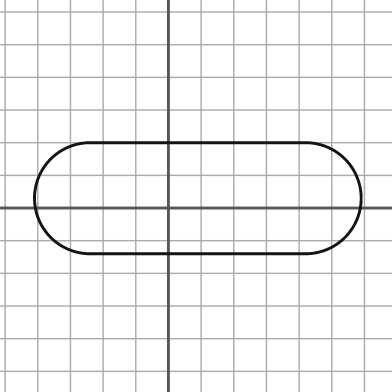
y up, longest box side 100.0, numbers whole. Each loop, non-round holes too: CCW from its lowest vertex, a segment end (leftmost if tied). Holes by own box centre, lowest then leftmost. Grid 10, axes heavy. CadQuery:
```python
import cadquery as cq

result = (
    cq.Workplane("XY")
    .moveTo(-24.0, -14.0)
    .lineTo(42.0, -14.0)
    .threePointArc((59.0, 3.0), (42.0, 20.0))
    .lineTo(-24.0, 20.0)
    .threePointArc((-41.0, 3.0), (-24.0, -14.0))
    .close()
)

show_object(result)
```